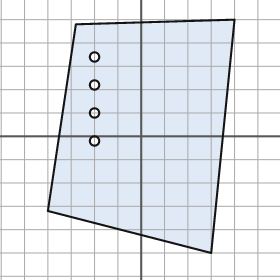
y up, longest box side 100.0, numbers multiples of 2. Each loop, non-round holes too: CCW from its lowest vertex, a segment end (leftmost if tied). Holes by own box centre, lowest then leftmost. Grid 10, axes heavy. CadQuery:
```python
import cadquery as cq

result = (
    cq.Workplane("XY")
    .moveTo(30.0, -50.0)
    .lineTo(40.0, 50.0)
    .lineTo(-28.0, 48.0)
    .lineTo(-40.0, -32.0)
    .close()
    .moveTo(-20.0, -2.0)
    .circle(2.0)
    .moveTo(-20.0, 10.0)
    .circle(2.0)
    .moveTo(-20.0, 22.0)
    .circle(2.0)
    .moveTo(-20.0, 34.0)
    .circle(2.0)
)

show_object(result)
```